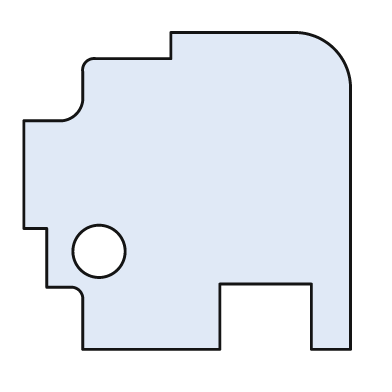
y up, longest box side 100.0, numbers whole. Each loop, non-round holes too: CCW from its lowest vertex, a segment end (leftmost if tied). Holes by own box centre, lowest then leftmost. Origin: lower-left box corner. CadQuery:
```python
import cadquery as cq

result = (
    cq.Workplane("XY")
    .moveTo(18.0, 0.0)
    .lineTo(60.0, 0.0)
    .lineTo(60.0, 20.0)
    .lineTo(88.0, 20.0)
    .lineTo(88.0, 0.0)
    .lineTo(100.0, 0.0)
    .lineTo(100.0, 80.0)
    .threePointArc((95.0, 92.0), (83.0, 97.0))
    .lineTo(45.0, 97.0)
    .lineTo(45.0, 89.0)
    .lineTo(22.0, 89.0)
    .threePointArc((19.0, 88.0), (18.0, 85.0))
    .lineTo(18.0, 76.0)
    .threePointArc((16.0, 72.0), (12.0, 70.0))
    .lineTo(0.0, 70.0)
    .lineTo(0.0, 37.0)
    .lineTo(7.0, 37.0)
    .lineTo(7.0, 19.0)
    .lineTo(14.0, 19.0)
    .threePointArc((17.0, 18.0), (18.0, 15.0))
    .close()
    .moveTo(23.0, 30.0)
    .circle(8.0)
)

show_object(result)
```